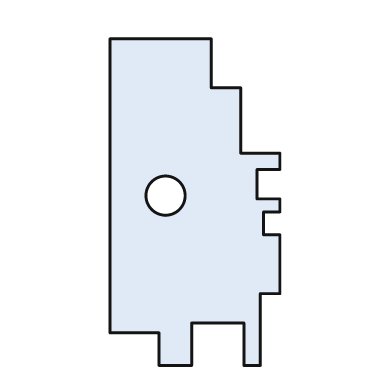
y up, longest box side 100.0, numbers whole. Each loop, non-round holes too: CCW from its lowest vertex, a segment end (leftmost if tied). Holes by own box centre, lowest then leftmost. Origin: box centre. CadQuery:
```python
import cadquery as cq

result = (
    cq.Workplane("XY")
    .moveTo(-11.0, -50.0)
    .lineTo(-1.0, -50.0)
    .lineTo(-1.0, -37.0)
    .lineTo(15.0, -37.0)
    .lineTo(15.0, -50.0)
    .lineTo(20.0, -50.0)
    .lineTo(20.0, -28.0)
    .lineTo(26.0, -28.0)
    .lineTo(26.0, -10.0)
    .lineTo(21.0, -10.0)
    .lineTo(21.0, -3.0)
    .lineTo(26.0, -3.0)
    .lineTo(26.0, 1.0)
    .lineTo(19.0, 1.0)
    .lineTo(19.0, 10.0)
    .lineTo(26.0, 10.0)
    .lineTo(26.0, 15.0)
    .lineTo(14.0, 15.0)
    .lineTo(14.0, 35.0)
    .lineTo(5.0, 35.0)
    .lineTo(5.0, 50.0)
    .lineTo(-26.0, 50.0)
    .lineTo(-26.0, -40.0)
    .lineTo(-11.0, -40.0)
    .close()
    .moveTo(-9.0, 2.0)
    .circle(6.0)
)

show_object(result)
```